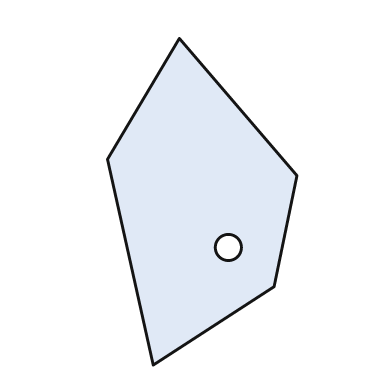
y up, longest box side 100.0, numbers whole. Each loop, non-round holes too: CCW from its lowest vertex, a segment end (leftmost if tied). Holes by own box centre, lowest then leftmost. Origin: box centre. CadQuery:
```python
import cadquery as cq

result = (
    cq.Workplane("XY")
    .moveTo(-15.0, -50.0)
    .lineTo(22.0, -26.0)
    .lineTo(29.0, 8.0)
    .lineTo(-7.0, 50.0)
    .lineTo(-29.0, 13.0)
    .close()
    .moveTo(8.0, -14.0)
    .circle(4.0)
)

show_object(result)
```